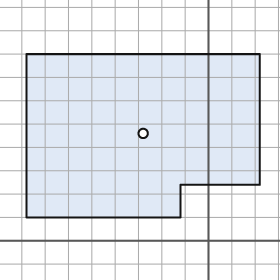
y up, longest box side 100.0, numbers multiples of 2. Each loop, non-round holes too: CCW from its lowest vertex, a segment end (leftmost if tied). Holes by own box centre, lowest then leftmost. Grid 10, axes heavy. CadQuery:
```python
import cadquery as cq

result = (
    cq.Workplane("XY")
    .moveTo(-78.0, 10.0)
    .lineTo(-12.0, 10.0)
    .lineTo(-12.0, 24.0)
    .lineTo(22.0, 24.0)
    .lineTo(22.0, 80.0)
    .lineTo(-78.0, 80.0)
    .close()
    .moveTo(-28.0, 46.0)
    .circle(2.0)
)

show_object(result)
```